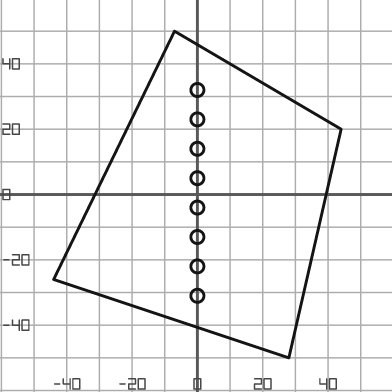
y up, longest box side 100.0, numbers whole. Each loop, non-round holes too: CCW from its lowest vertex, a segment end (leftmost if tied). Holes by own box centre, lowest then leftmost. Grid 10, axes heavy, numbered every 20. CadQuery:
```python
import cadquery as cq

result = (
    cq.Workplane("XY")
    .moveTo(28.0, -50.0)
    .lineTo(44.0, 20.0)
    .lineTo(-7.0, 50.0)
    .lineTo(-44.0, -26.0)
    .close()
    .moveTo(0.0, -31.0)
    .circle(2.0)
    .moveTo(0.0, -22.0)
    .circle(2.0)
    .moveTo(0.0, -13.0)
    .circle(2.0)
    .moveTo(0.0, -4.0)
    .circle(2.0)
    .moveTo(0.0, 5.0)
    .circle(2.0)
    .moveTo(0.0, 14.0)
    .circle(2.0)
    .moveTo(0.0, 23.0)
    .circle(2.0)
    .moveTo(0.0, 32.0)
    .circle(2.0)
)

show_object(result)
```